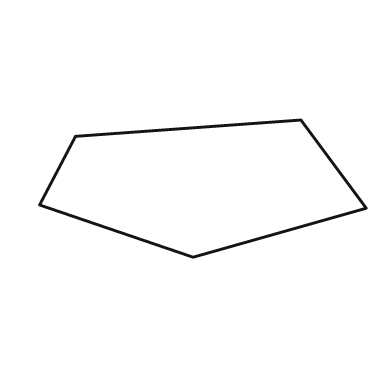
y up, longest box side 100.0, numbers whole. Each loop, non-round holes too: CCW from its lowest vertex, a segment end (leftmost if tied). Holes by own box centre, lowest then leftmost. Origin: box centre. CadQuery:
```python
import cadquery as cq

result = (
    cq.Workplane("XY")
    .moveTo(-3.0, -21.0)
    .lineTo(50.0, -6.0)
    .lineTo(30.0, 21.0)
    .lineTo(-39.0, 16.0)
    .lineTo(-50.0, -5.0)
    .close()
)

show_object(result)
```